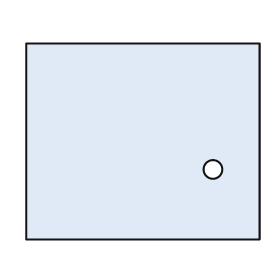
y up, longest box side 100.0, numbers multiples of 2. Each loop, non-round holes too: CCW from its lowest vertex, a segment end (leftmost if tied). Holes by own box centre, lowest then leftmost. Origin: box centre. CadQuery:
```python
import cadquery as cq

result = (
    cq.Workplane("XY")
    .moveTo(-50.0, -42.0)
    .lineTo(50.0, -42.0)
    .lineTo(50.0, 42.0)
    .lineTo(-50.0, 42.0)
    .close()
    .moveTo(30.0, -12.0)
    .circle(4.0)
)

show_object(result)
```